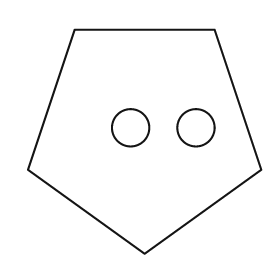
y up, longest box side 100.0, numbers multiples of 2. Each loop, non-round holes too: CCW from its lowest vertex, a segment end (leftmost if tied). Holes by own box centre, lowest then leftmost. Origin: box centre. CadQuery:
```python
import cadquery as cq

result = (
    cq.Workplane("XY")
    .moveTo(0.0, -48.0)
    .lineTo(50.0, -12.0)
    .lineTo(30.0, 48.0)
    .lineTo(-30.0, 48.0)
    .lineTo(-50.0, -12.0)
    .close()
    .moveTo(-6.0, 6.0)
    .circle(8.0)
    .moveTo(22.0, 6.0)
    .circle(8.0)
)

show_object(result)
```